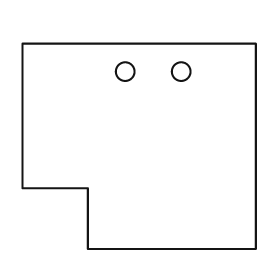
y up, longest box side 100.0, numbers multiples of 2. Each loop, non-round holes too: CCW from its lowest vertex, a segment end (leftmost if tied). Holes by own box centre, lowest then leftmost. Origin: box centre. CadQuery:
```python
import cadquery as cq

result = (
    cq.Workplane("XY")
    .moveTo(-22.0, -44.0)
    .lineTo(50.0, -44.0)
    .lineTo(50.0, 44.0)
    .lineTo(-50.0, 44.0)
    .lineTo(-50.0, -18.0)
    .lineTo(-22.0, -18.0)
    .close()
    .moveTo(-6.0, 32.0)
    .circle(4.0)
    .moveTo(18.0, 32.0)
    .circle(4.0)
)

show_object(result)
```